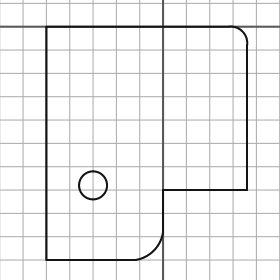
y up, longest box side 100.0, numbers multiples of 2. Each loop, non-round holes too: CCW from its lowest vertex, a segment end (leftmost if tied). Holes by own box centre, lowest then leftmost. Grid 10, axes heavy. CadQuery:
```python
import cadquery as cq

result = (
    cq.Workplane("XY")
    .moveTo(-50.0, -100.0)
    .lineTo(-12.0, -100.0)
    .threePointArc((-4.0, -96.0), (0.0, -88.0))
    .lineTo(0.0, -70.0)
    .lineTo(36.0, -70.0)
    .lineTo(36.0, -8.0)
    .threePointArc((34.0, -2.0), (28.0, 0.0))
    .lineTo(-50.0, 0.0)
    .close()
    .moveTo(-30.0, -68.0)
    .circle(6.0)
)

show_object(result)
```